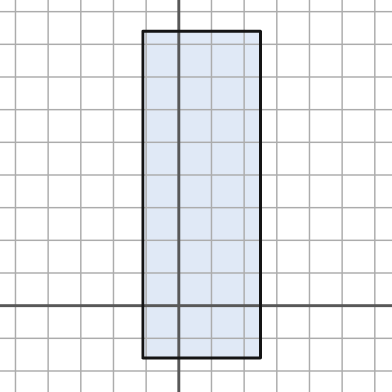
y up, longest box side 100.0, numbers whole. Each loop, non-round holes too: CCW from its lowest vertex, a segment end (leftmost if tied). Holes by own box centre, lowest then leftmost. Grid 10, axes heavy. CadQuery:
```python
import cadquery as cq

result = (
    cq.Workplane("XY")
    .moveTo(-11.0, -16.0)
    .lineTo(25.0, -16.0)
    .lineTo(25.0, 84.0)
    .lineTo(-11.0, 84.0)
    .close()
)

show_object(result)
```